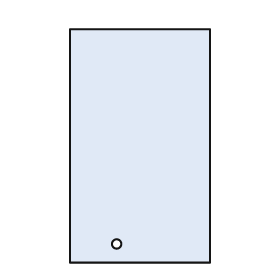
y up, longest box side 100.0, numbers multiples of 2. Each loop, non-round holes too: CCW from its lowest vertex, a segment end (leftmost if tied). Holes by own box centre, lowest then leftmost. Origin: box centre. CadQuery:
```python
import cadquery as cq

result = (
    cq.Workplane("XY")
    .moveTo(-30.0, -50.0)
    .lineTo(30.0, -50.0)
    .lineTo(30.0, 50.0)
    .lineTo(-30.0, 50.0)
    .close()
    .moveTo(-10.0, -42.0)
    .circle(2.0)
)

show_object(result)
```